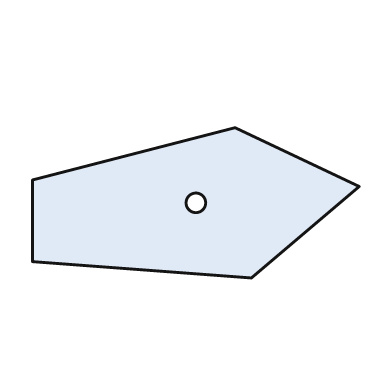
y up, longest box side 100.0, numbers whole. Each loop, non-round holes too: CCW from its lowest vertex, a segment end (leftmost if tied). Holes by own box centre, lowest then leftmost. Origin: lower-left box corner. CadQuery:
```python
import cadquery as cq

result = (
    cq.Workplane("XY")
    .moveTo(67.0, 0.0)
    .lineTo(100.0, 28.0)
    .lineTo(62.0, 46.0)
    .lineTo(0.0, 30.0)
    .lineTo(0.0, 5.0)
    .close()
    .moveTo(50.0, 23.0)
    .circle(3.0)
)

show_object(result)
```